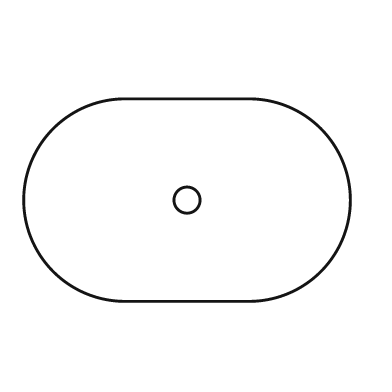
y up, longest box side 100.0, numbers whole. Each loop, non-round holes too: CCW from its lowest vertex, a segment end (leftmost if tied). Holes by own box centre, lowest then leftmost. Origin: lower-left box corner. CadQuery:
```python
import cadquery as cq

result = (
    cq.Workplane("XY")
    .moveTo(31.0, 0.0)
    .lineTo(69.0, 0.0)
    .threePointArc((100.0, 31.0), (69.0, 62.0))
    .lineTo(31.0, 62.0)
    .threePointArc((0.0, 31.0), (31.0, 0.0))
    .close()
    .moveTo(50.0, 31.0)
    .circle(4.0)
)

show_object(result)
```